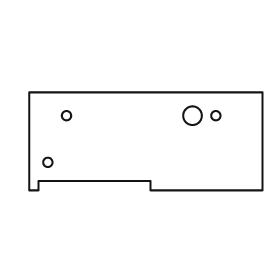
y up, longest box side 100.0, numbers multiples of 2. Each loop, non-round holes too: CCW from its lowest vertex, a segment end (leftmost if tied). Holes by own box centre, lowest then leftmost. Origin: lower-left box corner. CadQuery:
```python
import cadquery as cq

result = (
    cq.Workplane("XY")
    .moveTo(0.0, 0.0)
    .lineTo(4.0, 0.0)
    .lineTo(4.0, 4.0)
    .lineTo(52.0, 4.0)
    .lineTo(52.0, 0.0)
    .lineTo(100.0, 0.0)
    .lineTo(100.0, 42.0)
    .lineTo(0.0, 42.0)
    .close()
    .moveTo(8.0, 12.0)
    .circle(2.0)
    .moveTo(16.0, 32.0)
    .circle(2.0)
    .moveTo(70.0, 32.0)
    .circle(4.0)
    .moveTo(80.0, 32.0)
    .circle(2.0)
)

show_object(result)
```